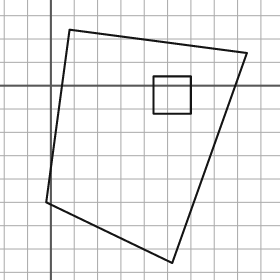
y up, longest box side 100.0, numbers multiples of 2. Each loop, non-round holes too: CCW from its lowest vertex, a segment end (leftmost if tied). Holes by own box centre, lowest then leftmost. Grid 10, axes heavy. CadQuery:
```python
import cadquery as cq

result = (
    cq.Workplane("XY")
    .moveTo(52.0, -76.0)
    .lineTo(84.0, 14.0)
    .lineTo(8.0, 24.0)
    .lineTo(-2.0, -50.0)
    .close()
    .moveTo(44.0, -12.0)
    .lineTo(60.0, -12.0)
    .lineTo(60.0, 4.0)
    .lineTo(44.0, 4.0)
    .close()
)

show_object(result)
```